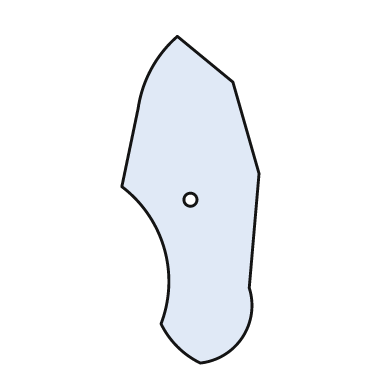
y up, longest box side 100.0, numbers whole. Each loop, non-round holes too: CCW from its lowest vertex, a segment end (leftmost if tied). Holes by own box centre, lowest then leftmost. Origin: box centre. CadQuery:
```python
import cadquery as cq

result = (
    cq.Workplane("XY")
    .moveTo(3.0, -50.0)
    .threePointArc((16.0, -42.0), (18.0, -27.0))
    .lineTo(21.0, 8.0)
    .lineTo(13.0, 36.0)
    .lineTo(-4.0, 50.0)
    .threePointArc((-12.0, 40.0), (-16.0, 28.0))
    .lineTo(-21.0, 4.0)
    .threePointArc((-8.0, -15.0), (-9.0, -38.0))
    .threePointArc((-4.0, -45.0), (3.0, -50.0))
    .close()
    .moveTo(0.0, 0.0)
    .circle(2.0)
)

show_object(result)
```